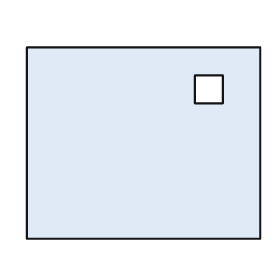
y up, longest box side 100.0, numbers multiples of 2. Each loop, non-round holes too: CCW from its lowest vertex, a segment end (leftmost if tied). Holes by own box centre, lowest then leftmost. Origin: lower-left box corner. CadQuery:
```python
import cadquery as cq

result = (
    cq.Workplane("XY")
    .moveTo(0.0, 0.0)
    .lineTo(100.0, 0.0)
    .lineTo(100.0, 82.0)
    .lineTo(0.0, 82.0)
    .close()
    .moveTo(72.0, 58.0)
    .lineTo(84.0, 58.0)
    .lineTo(84.0, 70.0)
    .lineTo(72.0, 70.0)
    .close()
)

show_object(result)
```